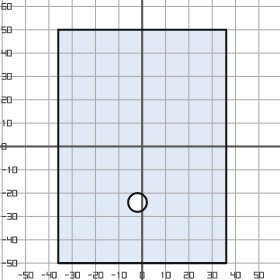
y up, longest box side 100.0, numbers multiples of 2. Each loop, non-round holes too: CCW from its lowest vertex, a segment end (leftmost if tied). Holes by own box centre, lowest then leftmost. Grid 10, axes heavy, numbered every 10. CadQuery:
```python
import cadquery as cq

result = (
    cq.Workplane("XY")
    .moveTo(-36.0, -50.0)
    .lineTo(36.0, -50.0)
    .lineTo(36.0, 50.0)
    .lineTo(-36.0, 50.0)
    .close()
    .moveTo(-2.0, -24.0)
    .circle(4.0)
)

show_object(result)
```